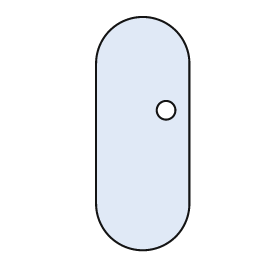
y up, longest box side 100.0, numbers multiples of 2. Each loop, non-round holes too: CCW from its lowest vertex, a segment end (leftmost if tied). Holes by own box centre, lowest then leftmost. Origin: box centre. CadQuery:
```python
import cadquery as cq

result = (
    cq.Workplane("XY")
    .moveTo(-20.0, -30.0)
    .threePointArc((0.0, -50.0), (20.0, -30.0))
    .lineTo(20.0, 30.0)
    .threePointArc((0.0, 50.0), (-20.0, 30.0))
    .close()
    .moveTo(10.0, 10.0)
    .circle(4.0)
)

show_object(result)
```